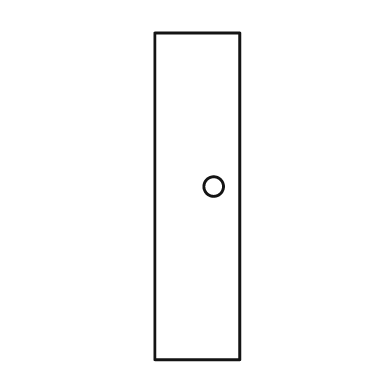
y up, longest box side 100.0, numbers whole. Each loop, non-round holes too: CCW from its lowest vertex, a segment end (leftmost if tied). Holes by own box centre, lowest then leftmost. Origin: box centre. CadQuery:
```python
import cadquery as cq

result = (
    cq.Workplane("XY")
    .moveTo(-13.0, -50.0)
    .lineTo(13.0, -50.0)
    .lineTo(13.0, 50.0)
    .lineTo(-13.0, 50.0)
    .close()
    .moveTo(5.0, 3.0)
    .circle(3.0)
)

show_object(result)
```